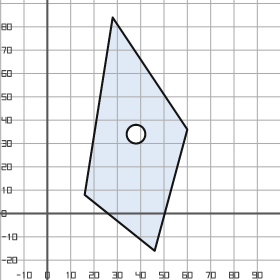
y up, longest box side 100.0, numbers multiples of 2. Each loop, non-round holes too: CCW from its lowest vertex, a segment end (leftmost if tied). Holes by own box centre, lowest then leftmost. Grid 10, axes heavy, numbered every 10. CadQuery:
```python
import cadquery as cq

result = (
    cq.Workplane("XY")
    .moveTo(46.0, -16.0)
    .lineTo(60.0, 36.0)
    .lineTo(28.0, 84.0)
    .lineTo(16.0, 8.0)
    .close()
    .moveTo(38.0, 34.0)
    .circle(4.0)
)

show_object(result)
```